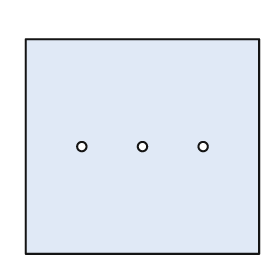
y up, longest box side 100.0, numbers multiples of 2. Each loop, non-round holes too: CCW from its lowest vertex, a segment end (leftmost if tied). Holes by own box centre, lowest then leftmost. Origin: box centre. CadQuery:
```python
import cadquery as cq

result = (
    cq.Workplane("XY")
    .moveTo(-50.0, -46.0)
    .lineTo(50.0, -46.0)
    .lineTo(50.0, 46.0)
    .lineTo(-50.0, 46.0)
    .close()
    .moveTo(-26.0, 0.0)
    .circle(2.0)
    .moveTo(0.0, 0.0)
    .circle(2.0)
    .moveTo(26.0, 0.0)
    .circle(2.0)
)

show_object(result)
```